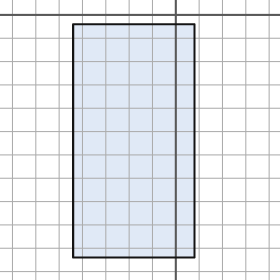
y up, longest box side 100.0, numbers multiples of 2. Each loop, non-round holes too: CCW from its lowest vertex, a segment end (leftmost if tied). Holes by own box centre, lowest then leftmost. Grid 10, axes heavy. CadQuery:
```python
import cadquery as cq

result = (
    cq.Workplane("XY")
    .moveTo(-44.0, -104.0)
    .lineTo(8.0, -104.0)
    .lineTo(8.0, -4.0)
    .lineTo(-44.0, -4.0)
    .close()
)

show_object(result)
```